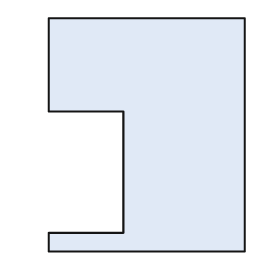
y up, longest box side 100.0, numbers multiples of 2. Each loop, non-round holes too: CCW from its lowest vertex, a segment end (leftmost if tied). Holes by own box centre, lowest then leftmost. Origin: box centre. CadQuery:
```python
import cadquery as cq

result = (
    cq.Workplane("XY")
    .moveTo(-42.0, -50.0)
    .lineTo(42.0, -50.0)
    .lineTo(42.0, 50.0)
    .lineTo(-42.0, 50.0)
    .lineTo(-42.0, 10.0)
    .lineTo(-10.0, 10.0)
    .lineTo(-10.0, -42.0)
    .lineTo(-42.0, -42.0)
    .close()
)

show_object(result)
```